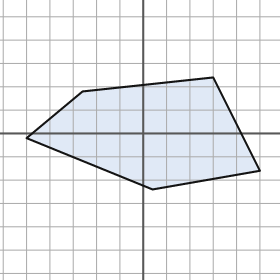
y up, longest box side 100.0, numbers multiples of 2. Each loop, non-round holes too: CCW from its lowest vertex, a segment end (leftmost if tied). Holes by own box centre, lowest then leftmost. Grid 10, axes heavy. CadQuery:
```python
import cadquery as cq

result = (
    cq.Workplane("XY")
    .moveTo(4.0, -24.0)
    .lineTo(50.0, -16.0)
    .lineTo(30.0, 24.0)
    .lineTo(-26.0, 18.0)
    .lineTo(-50.0, -2.0)
    .close()
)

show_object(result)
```